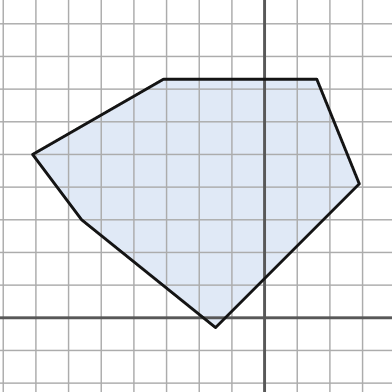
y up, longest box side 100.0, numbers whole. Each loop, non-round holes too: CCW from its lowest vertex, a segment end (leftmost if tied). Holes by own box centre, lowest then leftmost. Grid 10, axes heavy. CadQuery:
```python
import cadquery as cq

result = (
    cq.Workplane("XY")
    .moveTo(-15.0, -3.0)
    .lineTo(29.0, 41.0)
    .lineTo(16.0, 73.0)
    .lineTo(-31.0, 73.0)
    .lineTo(-71.0, 50.0)
    .lineTo(-56.0, 30.0)
    .close()
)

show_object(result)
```